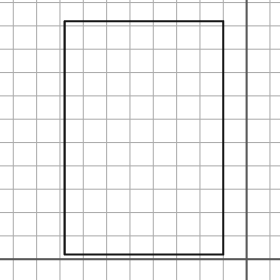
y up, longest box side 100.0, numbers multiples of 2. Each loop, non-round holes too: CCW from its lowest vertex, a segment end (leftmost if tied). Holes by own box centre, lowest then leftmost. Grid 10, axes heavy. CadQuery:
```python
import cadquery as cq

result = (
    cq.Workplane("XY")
    .moveTo(-78.0, 2.0)
    .lineTo(-10.0, 2.0)
    .lineTo(-10.0, 102.0)
    .lineTo(-78.0, 102.0)
    .close()
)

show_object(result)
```